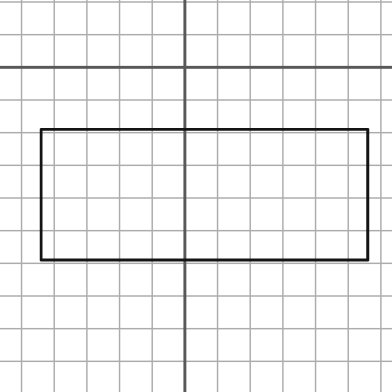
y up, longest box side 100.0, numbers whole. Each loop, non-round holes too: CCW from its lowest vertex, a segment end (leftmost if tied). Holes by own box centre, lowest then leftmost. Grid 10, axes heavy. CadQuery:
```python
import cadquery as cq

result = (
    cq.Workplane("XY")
    .moveTo(-44.0, -59.0)
    .lineTo(56.0, -59.0)
    .lineTo(56.0, -19.0)
    .lineTo(-44.0, -19.0)
    .close()
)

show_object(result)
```